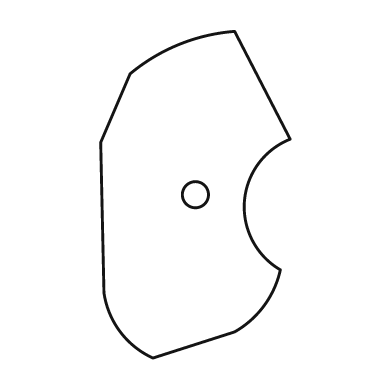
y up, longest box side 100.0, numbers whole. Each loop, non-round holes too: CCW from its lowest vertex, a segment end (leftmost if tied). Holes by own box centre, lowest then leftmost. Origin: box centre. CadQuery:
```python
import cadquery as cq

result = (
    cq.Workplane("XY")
    .moveTo(-13.0, -50.0)
    .lineTo(12.0, -42.0)
    .threePointArc((21.0, -34.0), (26.0, -23.0))
    .threePointArc((15.0, -2.0), (29.0, 17.0))
    .lineTo(12.0, 50.0)
    .threePointArc((-5.0, 46.0), (-20.0, 37.0))
    .lineTo(-29.0, 16.0)
    .lineTo(-28.0, -30.0)
    .threePointArc((-23.0, -42.0), (-13.0, -50.0))
    .close()
    .moveTo(0.0, 0.0)
    .circle(4.0)
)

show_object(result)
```